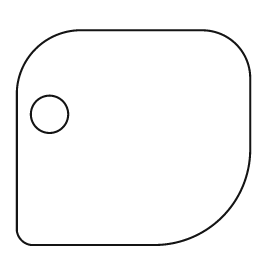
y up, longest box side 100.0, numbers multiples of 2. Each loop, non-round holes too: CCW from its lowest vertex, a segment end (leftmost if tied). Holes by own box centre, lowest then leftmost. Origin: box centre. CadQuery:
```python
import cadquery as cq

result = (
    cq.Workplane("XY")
    .moveTo(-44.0, -46.0)
    .lineTo(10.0, -46.0)
    .threePointArc((38.0, -34.0), (50.0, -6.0))
    .lineTo(50.0, 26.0)
    .threePointArc((44.0, 40.0), (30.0, 46.0))
    .lineTo(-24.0, 46.0)
    .threePointArc((-42.0, 38.0), (-50.0, 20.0))
    .lineTo(-50.0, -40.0)
    .threePointArc((-48.0, -44.0), (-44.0, -46.0))
    .close()
    .moveTo(-36.0, 10.0)
    .circle(8.0)
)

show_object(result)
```